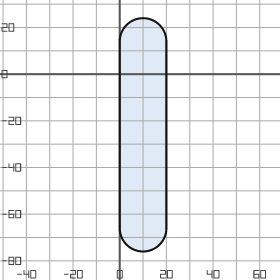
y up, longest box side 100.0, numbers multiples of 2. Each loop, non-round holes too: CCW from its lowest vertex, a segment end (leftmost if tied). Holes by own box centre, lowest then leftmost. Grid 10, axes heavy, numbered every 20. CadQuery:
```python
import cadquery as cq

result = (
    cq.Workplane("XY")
    .moveTo(0.0, -66.0)
    .threePointArc((10.0, -76.0), (20.0, -66.0))
    .lineTo(20.0, 14.0)
    .threePointArc((10.0, 24.0), (0.0, 14.0))
    .close()
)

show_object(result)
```